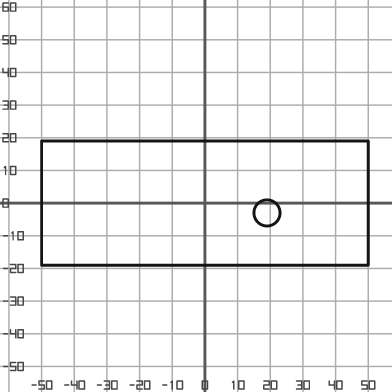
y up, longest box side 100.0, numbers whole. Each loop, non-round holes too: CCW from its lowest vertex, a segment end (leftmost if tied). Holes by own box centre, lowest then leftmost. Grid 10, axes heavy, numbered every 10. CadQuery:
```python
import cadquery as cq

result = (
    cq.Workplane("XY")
    .moveTo(-50.0, -19.0)
    .lineTo(50.0, -19.0)
    .lineTo(50.0, 19.0)
    .lineTo(-50.0, 19.0)
    .close()
    .moveTo(19.0, -3.0)
    .circle(4.0)
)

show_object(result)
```